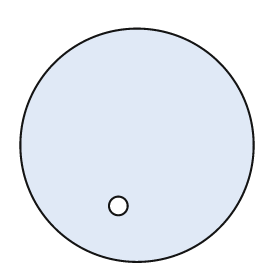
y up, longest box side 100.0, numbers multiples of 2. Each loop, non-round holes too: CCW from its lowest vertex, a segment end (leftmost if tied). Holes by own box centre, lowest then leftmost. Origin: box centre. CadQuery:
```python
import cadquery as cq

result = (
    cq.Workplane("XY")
    .moveTo(0.0, 0.0)
    .circle(50.0)
    .moveTo(-8.0, -26.0)
    .circle(4.0)
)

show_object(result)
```